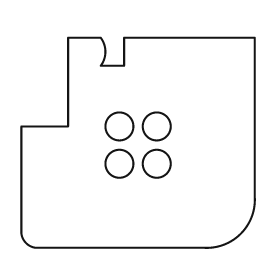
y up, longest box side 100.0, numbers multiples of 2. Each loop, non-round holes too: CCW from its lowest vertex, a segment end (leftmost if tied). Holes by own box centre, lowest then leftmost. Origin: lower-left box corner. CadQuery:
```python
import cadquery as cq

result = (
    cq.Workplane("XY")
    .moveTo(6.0, 0.0)
    .lineTo(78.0, 0.0)
    .threePointArc((94.0, 6.0), (100.0, 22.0))
    .lineTo(100.0, 90.0)
    .lineTo(44.0, 90.0)
    .lineTo(44.0, 78.0)
    .lineTo(34.0, 78.0)
    .threePointArc((36.0, 84.0), (34.0, 90.0))
    .lineTo(20.0, 90.0)
    .lineTo(20.0, 52.0)
    .lineTo(0.0, 52.0)
    .lineTo(0.0, 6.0)
    .threePointArc((2.0, 2.0), (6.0, 0.0))
    .close()
    .moveTo(42.0, 36.0)
    .circle(6.0)
    .moveTo(58.0, 36.0)
    .circle(6.0)
    .moveTo(42.0, 52.0)
    .circle(6.0)
    .moveTo(58.0, 52.0)
    .circle(6.0)
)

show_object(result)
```